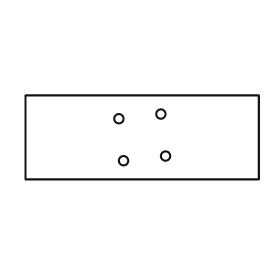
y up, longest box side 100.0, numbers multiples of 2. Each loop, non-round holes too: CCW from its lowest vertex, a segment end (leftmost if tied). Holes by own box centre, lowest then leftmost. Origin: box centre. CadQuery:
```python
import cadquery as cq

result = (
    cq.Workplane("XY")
    .moveTo(-50.0, -18.0)
    .lineTo(50.0, -18.0)
    .lineTo(50.0, 18.0)
    .lineTo(-50.0, 18.0)
    .close()
    .moveTo(-8.0, -10.0)
    .circle(2.0)
    .moveTo(10.0, -8.0)
    .circle(2.0)
    .moveTo(-10.0, 8.0)
    .circle(2.0)
    .moveTo(8.0, 10.0)
    .circle(2.0)
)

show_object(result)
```